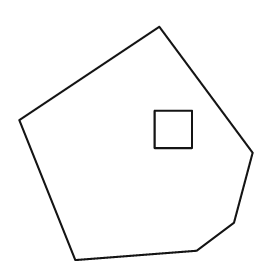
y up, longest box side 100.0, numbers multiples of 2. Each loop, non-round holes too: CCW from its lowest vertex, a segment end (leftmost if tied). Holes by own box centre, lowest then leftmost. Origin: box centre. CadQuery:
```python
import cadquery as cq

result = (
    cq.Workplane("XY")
    .moveTo(-26.0, -50.0)
    .lineTo(26.0, -46.0)
    .lineTo(42.0, -34.0)
    .lineTo(50.0, -4.0)
    .lineTo(10.0, 50.0)
    .lineTo(-50.0, 10.0)
    .close()
    .moveTo(8.0, -2.0)
    .lineTo(24.0, -2.0)
    .lineTo(24.0, 14.0)
    .lineTo(8.0, 14.0)
    .close()
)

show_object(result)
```